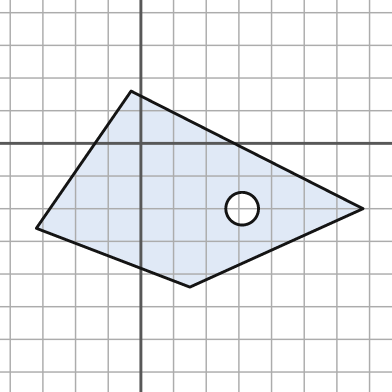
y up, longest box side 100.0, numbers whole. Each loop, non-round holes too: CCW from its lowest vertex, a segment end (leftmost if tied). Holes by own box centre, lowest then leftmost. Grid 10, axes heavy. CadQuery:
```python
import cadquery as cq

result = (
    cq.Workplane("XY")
    .moveTo(15.0, -44.0)
    .lineTo(68.0, -20.0)
    .lineTo(-3.0, 16.0)
    .lineTo(-32.0, -26.0)
    .close()
    .moveTo(31.0, -20.0)
    .circle(5.0)
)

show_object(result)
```